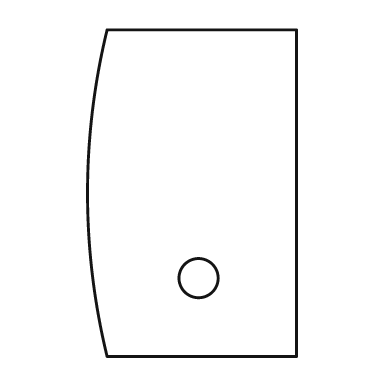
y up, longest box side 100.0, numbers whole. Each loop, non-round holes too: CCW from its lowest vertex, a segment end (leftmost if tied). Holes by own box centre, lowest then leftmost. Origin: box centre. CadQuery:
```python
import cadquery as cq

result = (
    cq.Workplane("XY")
    .moveTo(-26.0, -50.0)
    .lineTo(32.0, -50.0)
    .lineTo(32.0, 50.0)
    .lineTo(-26.0, 50.0)
    .threePointArc((-32.0, 0.0), (-26.0, -50.0))
    .close()
    .moveTo(2.0, -26.0)
    .circle(6.0)
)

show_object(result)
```